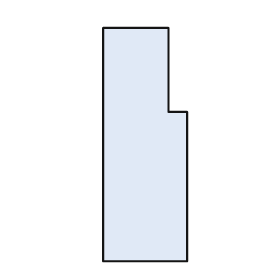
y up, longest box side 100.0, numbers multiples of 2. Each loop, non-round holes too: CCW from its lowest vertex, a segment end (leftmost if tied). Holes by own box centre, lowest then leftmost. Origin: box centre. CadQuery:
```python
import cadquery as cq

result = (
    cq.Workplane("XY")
    .moveTo(-18.0, -50.0)
    .lineTo(18.0, -50.0)
    .lineTo(18.0, 14.0)
    .lineTo(10.0, 14.0)
    .lineTo(10.0, 50.0)
    .lineTo(-18.0, 50.0)
    .close()
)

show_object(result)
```